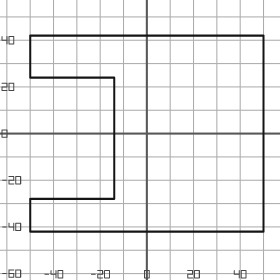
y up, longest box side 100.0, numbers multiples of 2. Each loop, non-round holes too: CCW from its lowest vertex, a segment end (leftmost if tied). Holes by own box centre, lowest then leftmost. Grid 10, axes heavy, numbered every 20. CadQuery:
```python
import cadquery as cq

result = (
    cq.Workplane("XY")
    .moveTo(-50.0, -42.0)
    .lineTo(50.0, -42.0)
    .lineTo(50.0, 42.0)
    .lineTo(-50.0, 42.0)
    .lineTo(-50.0, 24.0)
    .lineTo(-14.0, 24.0)
    .lineTo(-14.0, -28.0)
    .lineTo(-50.0, -28.0)
    .close()
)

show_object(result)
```